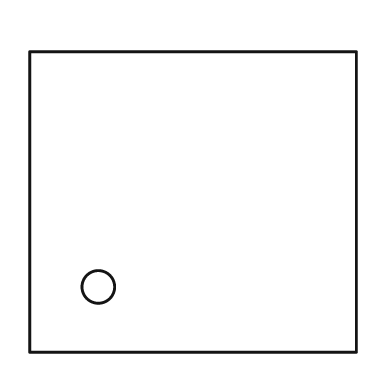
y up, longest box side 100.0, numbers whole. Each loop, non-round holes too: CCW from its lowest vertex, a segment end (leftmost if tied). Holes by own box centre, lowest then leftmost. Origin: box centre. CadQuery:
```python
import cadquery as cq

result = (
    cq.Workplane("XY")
    .moveTo(-50.0, -46.0)
    .lineTo(50.0, -46.0)
    .lineTo(50.0, 46.0)
    .lineTo(-50.0, 46.0)
    .close()
    .moveTo(-29.0, -26.0)
    .circle(5.0)
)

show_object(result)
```